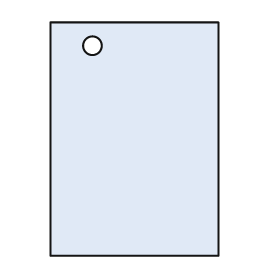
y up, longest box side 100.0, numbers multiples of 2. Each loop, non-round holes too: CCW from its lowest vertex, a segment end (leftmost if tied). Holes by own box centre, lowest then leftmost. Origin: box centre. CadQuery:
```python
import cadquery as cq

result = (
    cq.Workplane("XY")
    .moveTo(-36.0, -50.0)
    .lineTo(36.0, -50.0)
    .lineTo(36.0, 50.0)
    .lineTo(-36.0, 50.0)
    .close()
    .moveTo(-18.0, 40.0)
    .circle(4.0)
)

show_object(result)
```